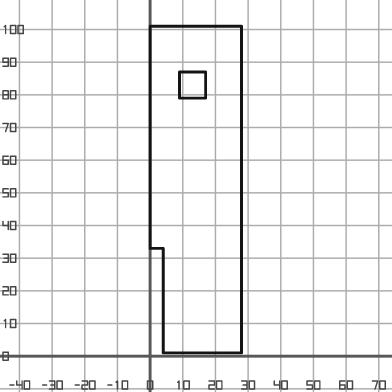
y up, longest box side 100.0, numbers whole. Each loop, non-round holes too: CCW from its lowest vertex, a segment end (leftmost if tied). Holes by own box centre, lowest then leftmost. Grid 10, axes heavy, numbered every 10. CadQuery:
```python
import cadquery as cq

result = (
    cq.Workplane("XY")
    .moveTo(4.0, 1.0)
    .lineTo(28.0, 1.0)
    .lineTo(28.0, 101.0)
    .lineTo(0.0, 101.0)
    .lineTo(0.0, 33.0)
    .lineTo(4.0, 33.0)
    .close()
    .moveTo(9.0, 79.0)
    .lineTo(17.0, 79.0)
    .lineTo(17.0, 87.0)
    .lineTo(9.0, 87.0)
    .close()
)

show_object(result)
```